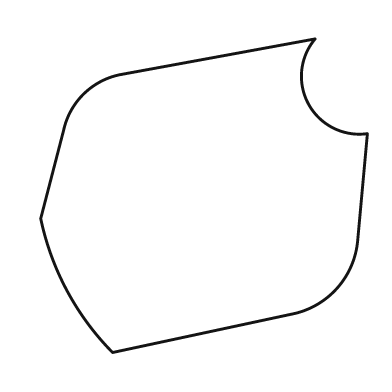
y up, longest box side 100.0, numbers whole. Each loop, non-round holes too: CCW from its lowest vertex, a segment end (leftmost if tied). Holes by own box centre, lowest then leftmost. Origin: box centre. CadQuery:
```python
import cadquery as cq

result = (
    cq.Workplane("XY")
    .moveTo(-28.0, -48.0)
    .lineTo(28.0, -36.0)
    .threePointArc((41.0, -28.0), (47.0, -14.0))
    .lineTo(50.0, 19.0)
    .threePointArc((32.0, 28.0), (34.0, 48.0))
    .lineTo(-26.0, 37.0)
    .threePointArc((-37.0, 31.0), (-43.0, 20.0))
    .lineTo(-50.0, -7.0)
    .threePointArc((-42.0, -29.0), (-28.0, -48.0))
    .close()
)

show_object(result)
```